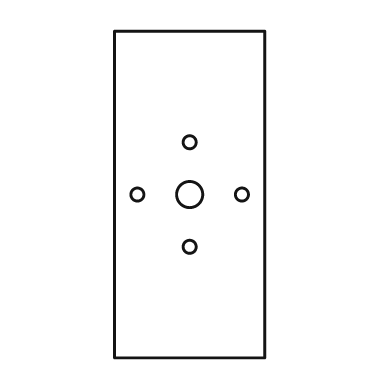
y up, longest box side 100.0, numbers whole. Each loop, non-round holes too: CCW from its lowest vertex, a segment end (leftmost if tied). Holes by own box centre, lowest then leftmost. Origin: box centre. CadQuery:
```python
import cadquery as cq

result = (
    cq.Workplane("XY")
    .moveTo(-23.0, -50.0)
    .lineTo(23.0, -50.0)
    .lineTo(23.0, 50.0)
    .lineTo(-23.0, 50.0)
    .close()
    .moveTo(0.0, -16.0)
    .circle(2.0)
    .moveTo(-16.0, 0.0)
    .circle(2.0)
    .moveTo(0.0, 0.0)
    .circle(4.0)
    .moveTo(16.0, 0.0)
    .circle(2.0)
    .moveTo(0.0, 16.0)
    .circle(2.0)
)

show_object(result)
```